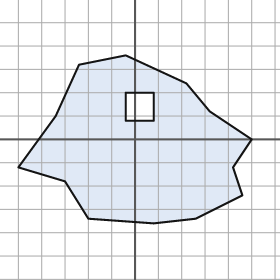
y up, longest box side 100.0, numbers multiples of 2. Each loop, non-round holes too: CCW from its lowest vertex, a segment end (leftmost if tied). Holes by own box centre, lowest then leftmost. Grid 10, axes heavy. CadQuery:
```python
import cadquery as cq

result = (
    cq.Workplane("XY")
    .moveTo(8.0, -36.0)
    .lineTo(26.0, -34.0)
    .lineTo(46.0, -24.0)
    .lineTo(42.0, -12.0)
    .lineTo(50.0, 0.0)
    .lineTo(32.0, 12.0)
    .lineTo(22.0, 24.0)
    .lineTo(-4.0, 36.0)
    .lineTo(-24.0, 32.0)
    .lineTo(-34.0, 10.0)
    .lineTo(-50.0, -12.0)
    .lineTo(-30.0, -18.0)
    .lineTo(-20.0, -34.0)
    .close()
    .moveTo(-4.0, 8.0)
    .lineTo(8.0, 8.0)
    .lineTo(8.0, 20.0)
    .lineTo(-4.0, 20.0)
    .close()
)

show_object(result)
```